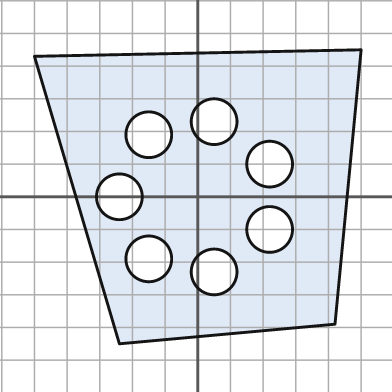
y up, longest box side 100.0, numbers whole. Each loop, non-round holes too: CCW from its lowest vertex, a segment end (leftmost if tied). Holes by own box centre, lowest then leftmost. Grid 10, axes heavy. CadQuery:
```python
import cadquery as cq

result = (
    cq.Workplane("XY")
    .moveTo(-24.0, -45.0)
    .lineTo(42.0, -39.0)
    .lineTo(50.0, 45.0)
    .lineTo(-50.0, 43.0)
    .close()
    .moveTo(5.0, -23.0)
    .circle(7.0)
    .moveTo(-15.0, -19.0)
    .circle(7.0)
    .moveTo(22.0, -10.0)
    .circle(7.0)
    .moveTo(-24.0, 0.0)
    .circle(7.0)
    .moveTo(22.0, 10.0)
    .circle(7.0)
    .moveTo(-15.0, 19.0)
    .circle(7.0)
    .moveTo(5.0, 23.0)
    .circle(7.0)
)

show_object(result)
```